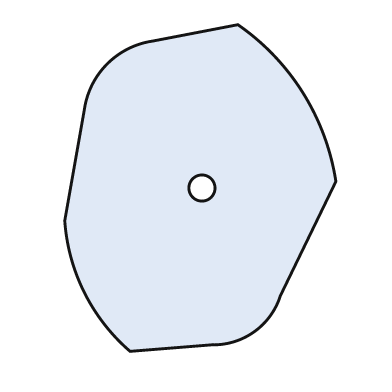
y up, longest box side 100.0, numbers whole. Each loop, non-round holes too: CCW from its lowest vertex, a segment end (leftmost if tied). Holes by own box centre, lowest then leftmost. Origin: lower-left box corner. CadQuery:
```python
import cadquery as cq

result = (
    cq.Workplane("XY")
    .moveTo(20.0, 0.0)
    .lineTo(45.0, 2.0)
    .threePointArc((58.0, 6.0), (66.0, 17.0))
    .lineTo(83.0, 52.0)
    .threePointArc((73.0, 79.0), (53.0, 100.0))
    .lineTo(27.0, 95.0)
    .threePointArc((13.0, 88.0), (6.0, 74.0))
    .lineTo(0.0, 40.0)
    .threePointArc((6.0, 18.0), (20.0, 0.0))
    .close()
    .moveTo(42.0, 50.0)
    .circle(4.0)
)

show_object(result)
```